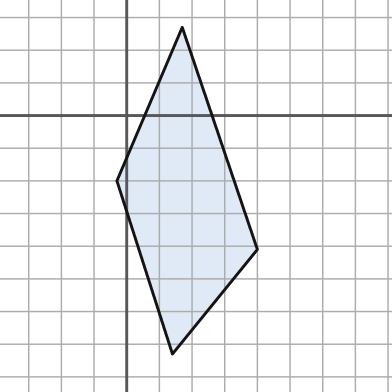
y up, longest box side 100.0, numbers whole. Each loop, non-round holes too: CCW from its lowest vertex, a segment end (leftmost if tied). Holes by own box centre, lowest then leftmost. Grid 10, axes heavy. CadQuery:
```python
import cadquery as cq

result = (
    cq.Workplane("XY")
    .moveTo(14.0, -73.0)
    .lineTo(40.0, -41.0)
    .lineTo(17.0, 27.0)
    .lineTo(-3.0, -20.0)
    .close()
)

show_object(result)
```